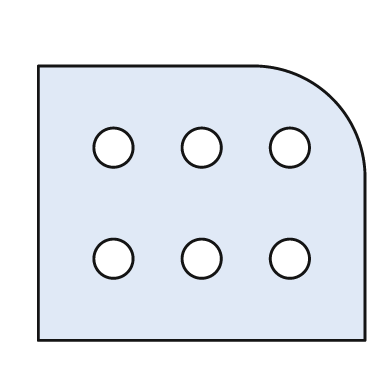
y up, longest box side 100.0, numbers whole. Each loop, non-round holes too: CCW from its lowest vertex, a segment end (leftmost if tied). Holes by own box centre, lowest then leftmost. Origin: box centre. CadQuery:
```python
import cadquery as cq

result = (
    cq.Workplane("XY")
    .moveTo(-50.0, -42.0)
    .lineTo(50.0, -42.0)
    .lineTo(50.0, 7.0)
    .threePointArc((40.0, 32.0), (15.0, 42.0))
    .lineTo(-50.0, 42.0)
    .close()
    .moveTo(-27.0, -17.0)
    .circle(6.0)
    .moveTo(0.0, -17.0)
    .circle(6.0)
    .moveTo(27.0, -17.0)
    .circle(6.0)
    .moveTo(-27.0, 17.0)
    .circle(6.0)
    .moveTo(0.0, 17.0)
    .circle(6.0)
    .moveTo(27.0, 17.0)
    .circle(6.0)
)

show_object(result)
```